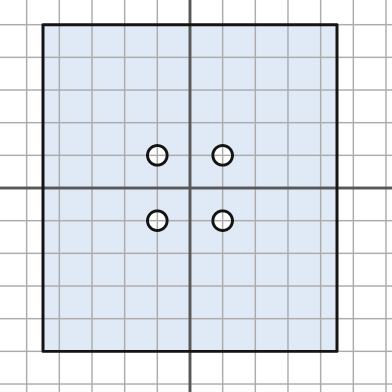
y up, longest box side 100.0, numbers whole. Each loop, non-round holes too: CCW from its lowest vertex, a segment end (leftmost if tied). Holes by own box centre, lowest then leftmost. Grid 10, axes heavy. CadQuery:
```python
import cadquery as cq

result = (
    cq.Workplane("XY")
    .moveTo(-45.0, -50.0)
    .lineTo(45.0, -50.0)
    .lineTo(45.0, 50.0)
    .lineTo(-45.0, 50.0)
    .close()
    .moveTo(-10.0, -10.0)
    .circle(3.0)
    .moveTo(10.0, -10.0)
    .circle(3.0)
    .moveTo(-10.0, 10.0)
    .circle(3.0)
    .moveTo(10.0, 10.0)
    .circle(3.0)
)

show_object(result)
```